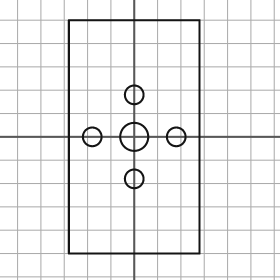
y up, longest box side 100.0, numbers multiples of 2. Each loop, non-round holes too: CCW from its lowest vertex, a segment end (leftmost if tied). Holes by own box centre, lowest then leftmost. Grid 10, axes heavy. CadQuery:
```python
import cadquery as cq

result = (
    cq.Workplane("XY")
    .moveTo(-28.0, -50.0)
    .lineTo(28.0, -50.0)
    .lineTo(28.0, 50.0)
    .lineTo(-28.0, 50.0)
    .close()
    .moveTo(0.0, -18.0)
    .circle(4.0)
    .moveTo(-18.0, 0.0)
    .circle(4.0)
    .moveTo(0.0, 0.0)
    .circle(6.0)
    .moveTo(18.0, 0.0)
    .circle(4.0)
    .moveTo(0.0, 18.0)
    .circle(4.0)
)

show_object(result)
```